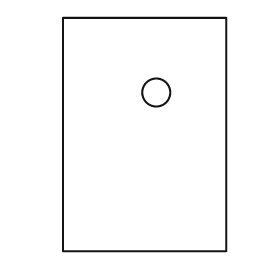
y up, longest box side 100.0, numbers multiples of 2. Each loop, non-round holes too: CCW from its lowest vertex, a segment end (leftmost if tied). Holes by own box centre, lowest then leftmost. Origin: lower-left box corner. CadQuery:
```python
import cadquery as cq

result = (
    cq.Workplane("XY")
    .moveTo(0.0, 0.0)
    .lineTo(70.0, 0.0)
    .lineTo(70.0, 100.0)
    .lineTo(0.0, 100.0)
    .close()
    .moveTo(40.0, 68.0)
    .circle(6.0)
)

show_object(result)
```